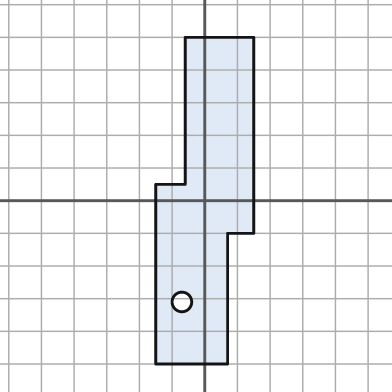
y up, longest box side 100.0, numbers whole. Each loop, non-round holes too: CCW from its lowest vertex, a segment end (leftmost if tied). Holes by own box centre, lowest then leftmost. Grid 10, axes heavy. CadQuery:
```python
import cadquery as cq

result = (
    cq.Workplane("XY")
    .moveTo(-15.0, -50.0)
    .lineTo(7.0, -50.0)
    .lineTo(7.0, -10.0)
    .lineTo(15.0, -10.0)
    .lineTo(15.0, 50.0)
    .lineTo(-6.0, 50.0)
    .lineTo(-6.0, 5.0)
    .lineTo(-15.0, 5.0)
    .close()
    .moveTo(-7.0, -31.0)
    .circle(3.0)
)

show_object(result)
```